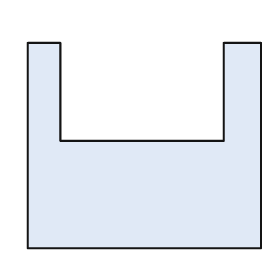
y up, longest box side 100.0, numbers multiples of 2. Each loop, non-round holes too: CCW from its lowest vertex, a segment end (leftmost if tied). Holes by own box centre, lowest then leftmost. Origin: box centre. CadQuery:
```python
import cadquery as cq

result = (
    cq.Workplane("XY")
    .moveTo(-50.0, -44.0)
    .lineTo(50.0, -44.0)
    .lineTo(50.0, 44.0)
    .lineTo(34.0, 44.0)
    .lineTo(34.0, 2.0)
    .lineTo(-36.0, 2.0)
    .lineTo(-36.0, 44.0)
    .lineTo(-50.0, 44.0)
    .close()
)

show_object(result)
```